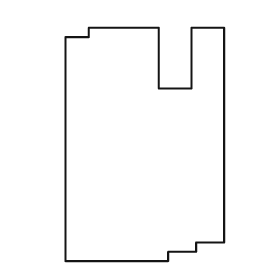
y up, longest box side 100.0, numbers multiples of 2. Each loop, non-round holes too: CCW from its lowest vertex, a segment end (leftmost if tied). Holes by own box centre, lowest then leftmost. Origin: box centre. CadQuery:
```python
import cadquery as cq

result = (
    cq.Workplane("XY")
    .moveTo(-34.0, -50.0)
    .lineTo(10.0, -50.0)
    .lineTo(10.0, -46.0)
    .lineTo(22.0, -46.0)
    .lineTo(22.0, -42.0)
    .lineTo(34.0, -42.0)
    .lineTo(34.0, 50.0)
    .lineTo(20.0, 50.0)
    .lineTo(20.0, 24.0)
    .lineTo(6.0, 24.0)
    .lineTo(6.0, 50.0)
    .lineTo(-24.0, 50.0)
    .lineTo(-24.0, 46.0)
    .lineTo(-34.0, 46.0)
    .close()
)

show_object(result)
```